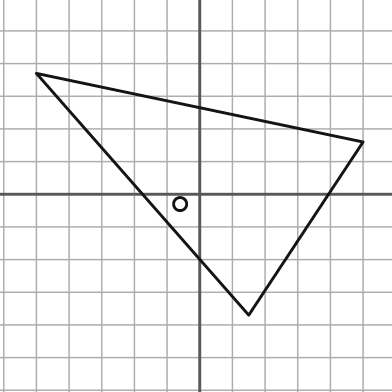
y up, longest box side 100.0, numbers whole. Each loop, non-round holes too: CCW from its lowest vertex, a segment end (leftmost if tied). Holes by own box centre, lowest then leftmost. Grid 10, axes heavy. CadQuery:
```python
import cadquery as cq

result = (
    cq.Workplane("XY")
    .moveTo(15.0, -37.0)
    .lineTo(50.0, 16.0)
    .lineTo(-50.0, 37.0)
    .close()
    .moveTo(-6.0, -3.0)
    .circle(2.0)
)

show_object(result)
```